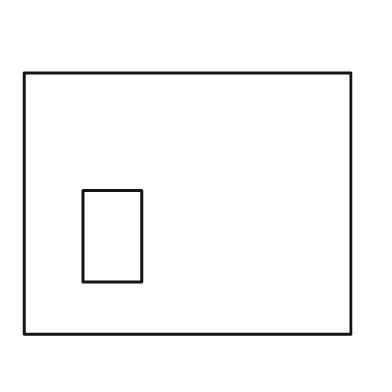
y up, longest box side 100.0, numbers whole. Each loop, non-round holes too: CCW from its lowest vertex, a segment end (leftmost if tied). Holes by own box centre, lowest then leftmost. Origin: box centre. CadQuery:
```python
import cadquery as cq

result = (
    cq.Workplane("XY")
    .moveTo(-50.0, -40.0)
    .lineTo(50.0, -40.0)
    .lineTo(50.0, 40.0)
    .lineTo(-50.0, 40.0)
    .close()
    .moveTo(-32.0, -24.0)
    .lineTo(-14.0, -24.0)
    .lineTo(-14.0, 4.0)
    .lineTo(-32.0, 4.0)
    .close()
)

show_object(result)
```